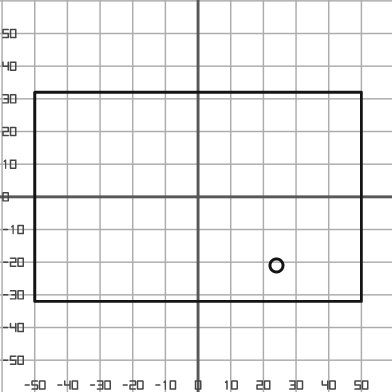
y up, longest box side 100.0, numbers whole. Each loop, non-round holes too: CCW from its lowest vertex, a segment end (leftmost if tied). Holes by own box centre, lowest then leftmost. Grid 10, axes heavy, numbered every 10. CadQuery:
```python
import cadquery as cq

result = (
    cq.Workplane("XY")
    .moveTo(-50.0, -32.0)
    .lineTo(50.0, -32.0)
    .lineTo(50.0, 32.0)
    .lineTo(-50.0, 32.0)
    .close()
    .moveTo(24.0, -21.0)
    .circle(2.0)
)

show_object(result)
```